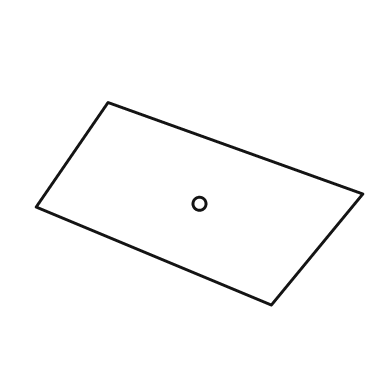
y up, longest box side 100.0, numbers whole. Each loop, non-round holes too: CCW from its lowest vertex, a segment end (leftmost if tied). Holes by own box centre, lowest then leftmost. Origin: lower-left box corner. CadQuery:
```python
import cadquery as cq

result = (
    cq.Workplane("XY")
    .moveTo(72.0, 0.0)
    .lineTo(100.0, 34.0)
    .lineTo(22.0, 62.0)
    .lineTo(0.0, 30.0)
    .close()
    .moveTo(50.0, 31.0)
    .circle(2.0)
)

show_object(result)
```